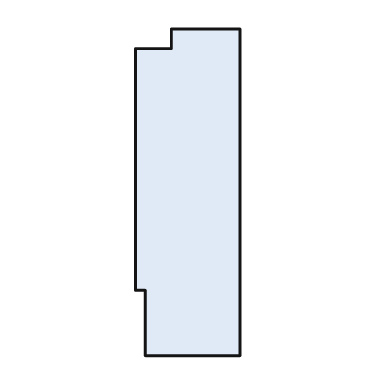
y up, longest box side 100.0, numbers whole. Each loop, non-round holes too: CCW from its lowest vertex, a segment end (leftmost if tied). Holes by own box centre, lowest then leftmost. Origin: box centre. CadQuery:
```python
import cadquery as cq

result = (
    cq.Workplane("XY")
    .moveTo(-13.0, -50.0)
    .lineTo(16.0, -50.0)
    .lineTo(16.0, 50.0)
    .lineTo(-5.0, 50.0)
    .lineTo(-5.0, 44.0)
    .lineTo(-16.0, 44.0)
    .lineTo(-16.0, -30.0)
    .lineTo(-13.0, -30.0)
    .close()
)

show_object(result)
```